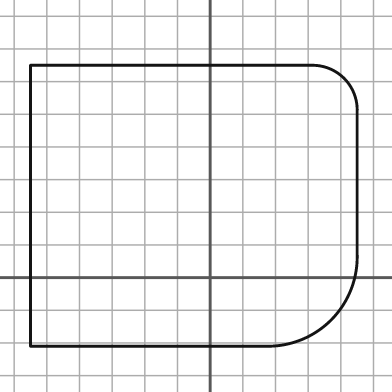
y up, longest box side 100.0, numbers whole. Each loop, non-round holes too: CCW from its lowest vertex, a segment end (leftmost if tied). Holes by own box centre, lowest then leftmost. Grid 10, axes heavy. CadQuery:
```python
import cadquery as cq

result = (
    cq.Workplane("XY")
    .moveTo(-55.0, -21.0)
    .lineTo(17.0, -21.0)
    .threePointArc((37.0, -13.0), (45.0, 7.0))
    .lineTo(45.0, 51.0)
    .threePointArc((41.0, 61.0), (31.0, 65.0))
    .lineTo(-55.0, 65.0)
    .close()
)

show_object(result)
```